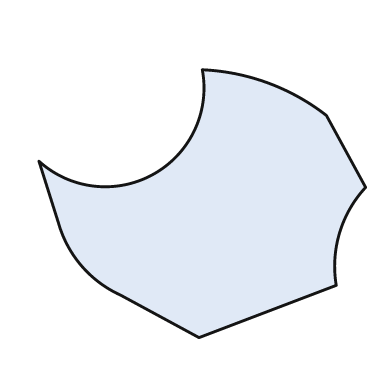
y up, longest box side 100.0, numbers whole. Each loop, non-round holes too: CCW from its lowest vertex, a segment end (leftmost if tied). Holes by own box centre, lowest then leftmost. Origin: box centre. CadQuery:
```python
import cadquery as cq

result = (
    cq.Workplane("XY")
    .moveTo(-1.0, -41.0)
    .lineTo(41.0, -25.0)
    .threePointArc((42.0, -9.0), (50.0, 5.0))
    .lineTo(38.0, 27.0)
    .threePointArc((20.0, 37.0), (0.0, 41.0))
    .threePointArc((-15.0, 9.0), (-50.0, 13.0))
    .lineTo(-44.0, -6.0)
    .threePointArc((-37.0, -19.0), (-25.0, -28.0))
    .close()
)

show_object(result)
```